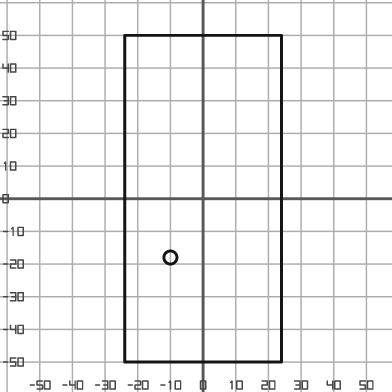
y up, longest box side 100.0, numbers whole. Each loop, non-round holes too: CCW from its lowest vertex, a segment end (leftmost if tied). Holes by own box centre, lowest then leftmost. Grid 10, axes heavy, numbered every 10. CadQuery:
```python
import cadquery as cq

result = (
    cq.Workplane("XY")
    .moveTo(-24.0, -50.0)
    .lineTo(24.0, -50.0)
    .lineTo(24.0, 50.0)
    .lineTo(-24.0, 50.0)
    .close()
    .moveTo(-10.0, -18.0)
    .circle(2.0)
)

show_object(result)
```